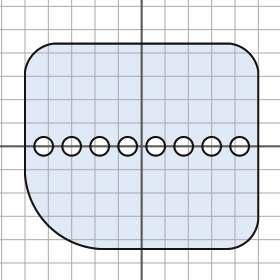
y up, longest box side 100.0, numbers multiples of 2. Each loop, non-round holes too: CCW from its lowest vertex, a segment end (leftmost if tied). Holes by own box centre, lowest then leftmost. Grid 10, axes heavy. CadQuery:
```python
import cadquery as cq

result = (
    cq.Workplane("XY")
    .moveTo(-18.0, -44.0)
    .lineTo(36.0, -44.0)
    .threePointArc((46.0, -40.0), (50.0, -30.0))
    .lineTo(50.0, 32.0)
    .threePointArc((46.0, 40.0), (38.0, 44.0))
    .lineTo(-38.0, 44.0)
    .threePointArc((-46.0, 40.0), (-50.0, 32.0))
    .lineTo(-50.0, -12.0)
    .threePointArc((-40.0, -34.0), (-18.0, -44.0))
    .close()
    .moveTo(-42.0, 0.0)
    .circle(4.0)
    .moveTo(-30.0, 0.0)
    .circle(4.0)
    .moveTo(-18.0, 0.0)
    .circle(4.0)
    .moveTo(-6.0, 0.0)
    .circle(4.0)
    .moveTo(6.0, 0.0)
    .circle(4.0)
    .moveTo(18.0, 0.0)
    .circle(4.0)
    .moveTo(30.0, 0.0)
    .circle(4.0)
    .moveTo(42.0, 0.0)
    .circle(4.0)
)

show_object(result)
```